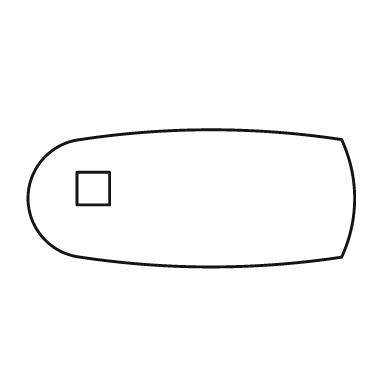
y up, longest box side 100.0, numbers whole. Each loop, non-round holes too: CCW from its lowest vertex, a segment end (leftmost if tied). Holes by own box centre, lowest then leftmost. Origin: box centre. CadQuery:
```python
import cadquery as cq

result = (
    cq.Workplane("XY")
    .moveTo(-34.0, -18.0)
    .threePointArc((6.0, -21.0), (46.0, -18.0))
    .threePointArc((50.0, 0.0), (46.0, 18.0))
    .threePointArc((6.0, 21.0), (-34.0, 18.0))
    .threePointArc((-50.0, 0.0), (-34.0, -18.0))
    .close()
    .moveTo(-35.0, -2.0)
    .lineTo(-25.0, -2.0)
    .lineTo(-25.0, 8.0)
    .lineTo(-35.0, 8.0)
    .close()
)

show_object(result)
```